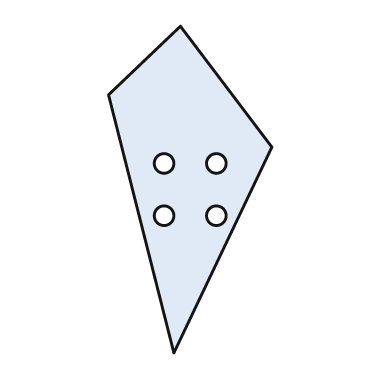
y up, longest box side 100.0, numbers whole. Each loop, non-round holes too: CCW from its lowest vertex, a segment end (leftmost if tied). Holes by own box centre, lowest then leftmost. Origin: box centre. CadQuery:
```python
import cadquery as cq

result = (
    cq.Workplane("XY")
    .moveTo(-5.0, -50.0)
    .lineTo(25.0, 13.0)
    .lineTo(-3.0, 50.0)
    .lineTo(-25.0, 29.0)
    .close()
    .moveTo(-8.0, -8.0)
    .circle(3.0)
    .moveTo(8.0, -8.0)
    .circle(3.0)
    .moveTo(-8.0, 8.0)
    .circle(3.0)
    .moveTo(8.0, 8.0)
    .circle(3.0)
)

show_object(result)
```